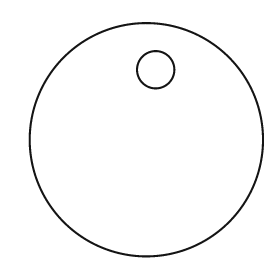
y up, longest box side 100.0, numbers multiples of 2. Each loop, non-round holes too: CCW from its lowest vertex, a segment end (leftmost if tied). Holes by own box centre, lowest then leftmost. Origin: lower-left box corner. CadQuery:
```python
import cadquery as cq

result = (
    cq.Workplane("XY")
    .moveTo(50.0, 50.0)
    .circle(50.0)
    .moveTo(54.0, 80.0)
    .circle(8.0)
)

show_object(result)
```